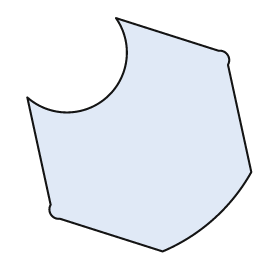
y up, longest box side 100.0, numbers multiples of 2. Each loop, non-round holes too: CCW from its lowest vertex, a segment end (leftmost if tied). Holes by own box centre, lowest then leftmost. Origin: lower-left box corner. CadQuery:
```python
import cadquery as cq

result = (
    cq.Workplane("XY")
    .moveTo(58.0, 0.0)
    .threePointArc((80.0, 14.0), (96.0, 34.0))
    .lineTo(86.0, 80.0)
    .threePointArc((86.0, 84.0), (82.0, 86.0))
    .lineTo(38.0, 100.0)
    .threePointArc((34.0, 66.0), (0.0, 66.0))
    .lineTo(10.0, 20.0)
    .threePointArc((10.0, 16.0), (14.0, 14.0))
    .close()
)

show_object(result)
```